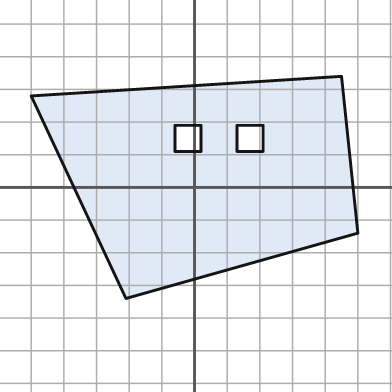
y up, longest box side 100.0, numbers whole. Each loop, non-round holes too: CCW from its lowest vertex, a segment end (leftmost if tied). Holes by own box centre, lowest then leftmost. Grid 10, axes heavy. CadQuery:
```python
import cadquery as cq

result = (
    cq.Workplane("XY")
    .moveTo(-21.0, -34.0)
    .lineTo(50.0, -14.0)
    .lineTo(45.0, 34.0)
    .lineTo(-50.0, 28.0)
    .close()
    .moveTo(-6.0, 11.0)
    .lineTo(2.0, 11.0)
    .lineTo(2.0, 19.0)
    .lineTo(-6.0, 19.0)
    .close()
    .moveTo(13.0, 11.0)
    .lineTo(21.0, 11.0)
    .lineTo(21.0, 19.0)
    .lineTo(13.0, 19.0)
    .close()
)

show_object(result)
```